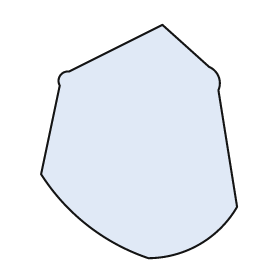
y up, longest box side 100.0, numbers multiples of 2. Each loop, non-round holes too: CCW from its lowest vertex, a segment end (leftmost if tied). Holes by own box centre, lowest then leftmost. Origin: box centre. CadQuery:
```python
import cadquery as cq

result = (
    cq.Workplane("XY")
    .moveTo(4.0, -50.0)
    .threePointArc((26.0, -44.0), (42.0, -28.0))
    .lineTo(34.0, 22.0)
    .threePointArc((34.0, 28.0), (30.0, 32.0))
    .lineTo(10.0, 50.0)
    .lineTo(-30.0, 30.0)
    .threePointArc((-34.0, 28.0), (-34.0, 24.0))
    .lineTo(-42.0, -14.0)
    .threePointArc((-22.0, -36.0), (4.0, -50.0))
    .close()
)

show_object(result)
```